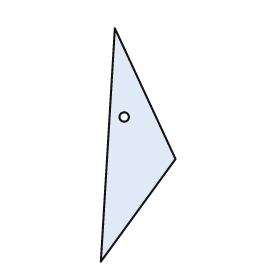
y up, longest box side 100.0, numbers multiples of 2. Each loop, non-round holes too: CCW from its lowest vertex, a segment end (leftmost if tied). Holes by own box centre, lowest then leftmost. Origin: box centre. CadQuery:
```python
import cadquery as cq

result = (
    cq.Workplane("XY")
    .moveTo(-16.0, -50.0)
    .lineTo(16.0, -6.0)
    .lineTo(-10.0, 50.0)
    .close()
    .moveTo(-6.0, 12.0)
    .circle(2.0)
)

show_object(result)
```